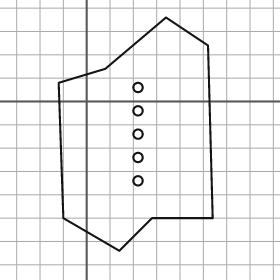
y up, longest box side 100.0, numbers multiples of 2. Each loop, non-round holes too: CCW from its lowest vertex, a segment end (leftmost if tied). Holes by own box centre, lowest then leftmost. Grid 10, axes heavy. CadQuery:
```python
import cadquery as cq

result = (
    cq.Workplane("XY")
    .moveTo(14.0, -64.0)
    .lineTo(28.0, -50.0)
    .lineTo(54.0, -50.0)
    .lineTo(52.0, 24.0)
    .lineTo(34.0, 36.0)
    .lineTo(8.0, 14.0)
    .lineTo(-12.0, 8.0)
    .lineTo(-10.0, -50.0)
    .close()
    .moveTo(22.0, -34.0)
    .circle(2.0)
    .moveTo(22.0, -24.0)
    .circle(2.0)
    .moveTo(22.0, -14.0)
    .circle(2.0)
    .moveTo(22.0, -4.0)
    .circle(2.0)
    .moveTo(22.0, 6.0)
    .circle(2.0)
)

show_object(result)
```